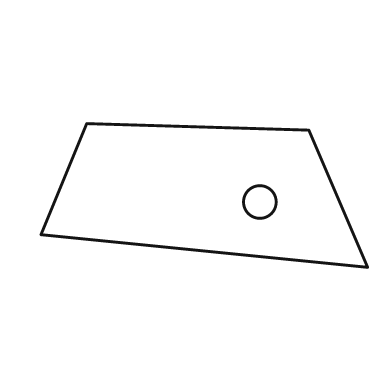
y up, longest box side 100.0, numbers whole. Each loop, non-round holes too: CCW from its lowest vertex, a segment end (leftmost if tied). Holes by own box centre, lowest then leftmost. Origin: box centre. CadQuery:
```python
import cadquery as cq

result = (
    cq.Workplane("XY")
    .moveTo(50.0, -22.0)
    .lineTo(32.0, 20.0)
    .lineTo(-36.0, 22.0)
    .lineTo(-50.0, -12.0)
    .close()
    .moveTo(17.0, -2.0)
    .circle(5.0)
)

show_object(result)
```